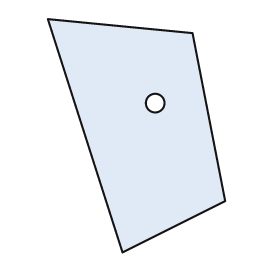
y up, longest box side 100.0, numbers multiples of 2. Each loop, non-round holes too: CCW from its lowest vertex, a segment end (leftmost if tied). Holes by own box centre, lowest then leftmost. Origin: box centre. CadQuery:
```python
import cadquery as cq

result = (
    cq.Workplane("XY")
    .moveTo(-6.0, -50.0)
    .lineTo(38.0, -28.0)
    .lineTo(24.0, 44.0)
    .lineTo(-38.0, 50.0)
    .close()
    .moveTo(8.0, 14.0)
    .circle(4.0)
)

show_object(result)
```